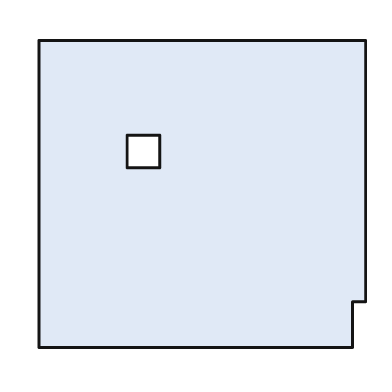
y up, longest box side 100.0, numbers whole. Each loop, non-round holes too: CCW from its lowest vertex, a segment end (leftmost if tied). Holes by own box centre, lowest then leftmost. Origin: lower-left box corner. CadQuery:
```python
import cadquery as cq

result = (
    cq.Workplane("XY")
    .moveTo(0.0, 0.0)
    .lineTo(96.0, 0.0)
    .lineTo(96.0, 14.0)
    .lineTo(100.0, 14.0)
    .lineTo(100.0, 94.0)
    .lineTo(0.0, 94.0)
    .close()
    .moveTo(27.0, 55.0)
    .lineTo(37.0, 55.0)
    .lineTo(37.0, 65.0)
    .lineTo(27.0, 65.0)
    .close()
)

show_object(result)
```